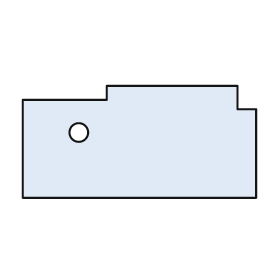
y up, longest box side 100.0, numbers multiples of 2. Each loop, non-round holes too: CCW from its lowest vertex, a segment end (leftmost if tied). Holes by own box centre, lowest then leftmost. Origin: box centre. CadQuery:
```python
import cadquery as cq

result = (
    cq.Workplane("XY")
    .moveTo(-50.0, -24.0)
    .lineTo(50.0, -24.0)
    .lineTo(50.0, 14.0)
    .lineTo(42.0, 14.0)
    .lineTo(42.0, 24.0)
    .lineTo(-14.0, 24.0)
    .lineTo(-14.0, 18.0)
    .lineTo(-50.0, 18.0)
    .close()
    .moveTo(-26.0, 4.0)
    .circle(4.0)
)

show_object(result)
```